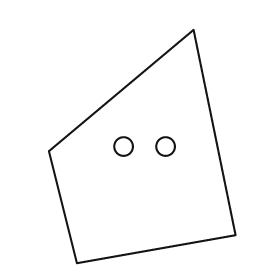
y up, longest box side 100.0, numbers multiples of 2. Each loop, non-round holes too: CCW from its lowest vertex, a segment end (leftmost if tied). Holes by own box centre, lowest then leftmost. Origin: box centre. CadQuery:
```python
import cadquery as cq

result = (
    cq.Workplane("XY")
    .moveTo(-28.0, -50.0)
    .lineTo(40.0, -38.0)
    .lineTo(22.0, 50.0)
    .lineTo(-40.0, -2.0)
    .close()
    .moveTo(-8.0, 0.0)
    .circle(4.0)
    .moveTo(10.0, 0.0)
    .circle(4.0)
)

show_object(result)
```